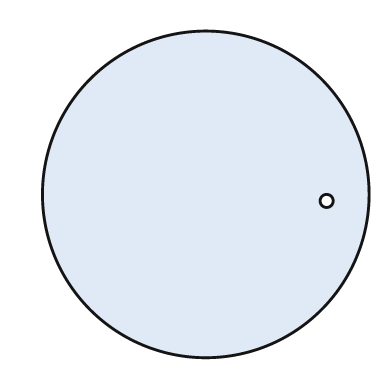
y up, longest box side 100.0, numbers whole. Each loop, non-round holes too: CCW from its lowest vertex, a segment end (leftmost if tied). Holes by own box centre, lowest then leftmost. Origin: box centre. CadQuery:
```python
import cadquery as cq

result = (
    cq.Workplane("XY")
    .moveTo(0.0, 0.0)
    .circle(50.0)
    .moveTo(37.0, -2.0)
    .circle(2.0)
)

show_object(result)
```